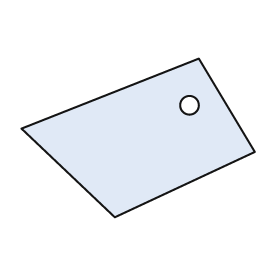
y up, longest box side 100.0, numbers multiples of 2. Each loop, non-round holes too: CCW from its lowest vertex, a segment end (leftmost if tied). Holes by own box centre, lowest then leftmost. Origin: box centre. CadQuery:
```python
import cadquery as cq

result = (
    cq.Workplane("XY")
    .moveTo(-10.0, -34.0)
    .lineTo(50.0, -6.0)
    .lineTo(26.0, 34.0)
    .lineTo(-50.0, 4.0)
    .close()
    .moveTo(22.0, 14.0)
    .circle(4.0)
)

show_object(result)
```